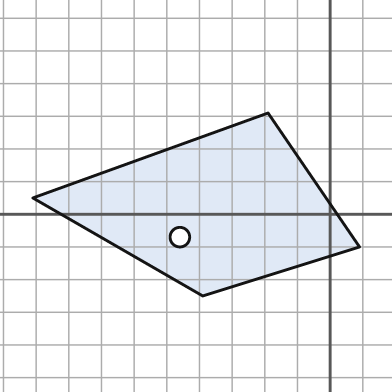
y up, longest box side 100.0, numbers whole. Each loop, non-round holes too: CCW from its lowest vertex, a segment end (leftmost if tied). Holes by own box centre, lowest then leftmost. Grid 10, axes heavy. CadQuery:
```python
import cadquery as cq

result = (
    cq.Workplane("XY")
    .moveTo(-39.0, -25.0)
    .lineTo(9.0, -10.0)
    .lineTo(-19.0, 31.0)
    .lineTo(-91.0, 5.0)
    .close()
    .moveTo(-46.0, -7.0)
    .circle(3.0)
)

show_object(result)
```